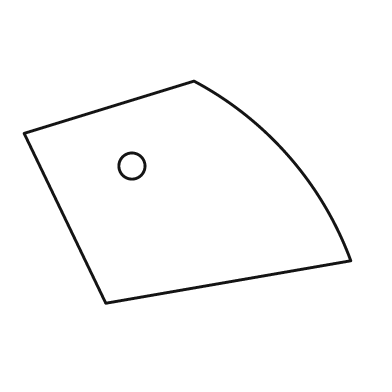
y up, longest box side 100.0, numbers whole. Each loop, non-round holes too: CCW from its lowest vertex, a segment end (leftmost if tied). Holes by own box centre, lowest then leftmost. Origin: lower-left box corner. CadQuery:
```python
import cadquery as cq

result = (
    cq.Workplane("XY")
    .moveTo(25.0, 0.0)
    .lineTo(100.0, 13.0)
    .threePointArc((81.0, 45.0), (52.0, 68.0))
    .lineTo(0.0, 52.0)
    .close()
    .moveTo(33.0, 42.0)
    .circle(4.0)
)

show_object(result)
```